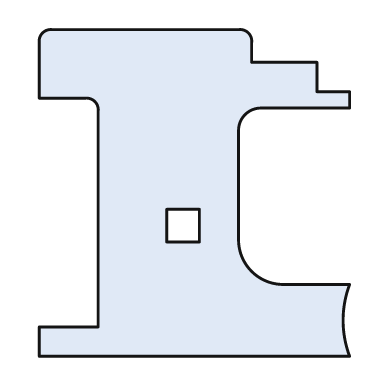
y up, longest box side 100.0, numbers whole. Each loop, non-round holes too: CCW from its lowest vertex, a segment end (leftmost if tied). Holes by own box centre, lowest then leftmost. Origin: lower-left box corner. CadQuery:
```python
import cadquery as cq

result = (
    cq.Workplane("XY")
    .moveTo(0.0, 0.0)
    .lineTo(95.0, 0.0)
    .threePointArc((93.0, 11.0), (95.0, 22.0))
    .lineTo(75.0, 22.0)
    .threePointArc((65.0, 26.0), (61.0, 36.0))
    .lineTo(61.0, 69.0)
    .threePointArc((63.0, 74.0), (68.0, 76.0))
    .lineTo(95.0, 76.0)
    .lineTo(95.0, 81.0)
    .lineTo(85.0, 81.0)
    .lineTo(85.0, 90.0)
    .lineTo(65.0, 90.0)
    .lineTo(65.0, 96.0)
    .threePointArc((64.0, 99.0), (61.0, 100.0))
    .lineTo(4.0, 100.0)
    .threePointArc((1.0, 99.0), (0.0, 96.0))
    .lineTo(0.0, 79.0)
    .lineTo(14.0, 79.0)
    .threePointArc((17.0, 78.0), (18.0, 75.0))
    .lineTo(18.0, 9.0)
    .lineTo(0.0, 9.0)
    .close()
    .moveTo(39.0, 35.0)
    .lineTo(49.0, 35.0)
    .lineTo(49.0, 45.0)
    .lineTo(39.0, 45.0)
    .close()
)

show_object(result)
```